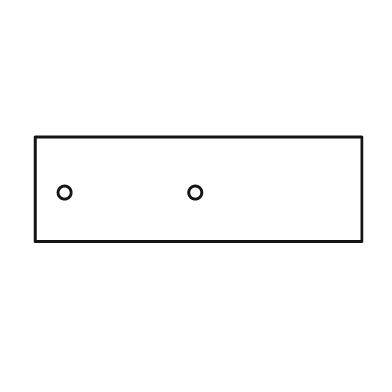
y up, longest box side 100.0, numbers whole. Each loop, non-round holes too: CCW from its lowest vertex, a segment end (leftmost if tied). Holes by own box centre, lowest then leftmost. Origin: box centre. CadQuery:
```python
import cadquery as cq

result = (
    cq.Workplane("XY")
    .moveTo(-50.0, -16.0)
    .lineTo(50.0, -16.0)
    .lineTo(50.0, 16.0)
    .lineTo(-50.0, 16.0)
    .close()
    .moveTo(-41.0, -1.0)
    .circle(2.0)
    .moveTo(-1.0, -1.0)
    .circle(2.0)
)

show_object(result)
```